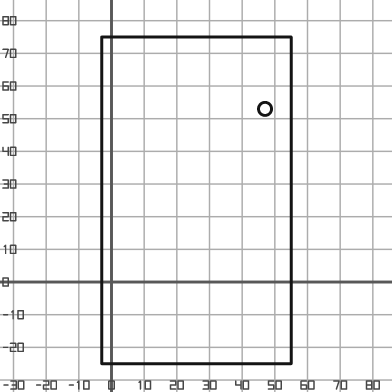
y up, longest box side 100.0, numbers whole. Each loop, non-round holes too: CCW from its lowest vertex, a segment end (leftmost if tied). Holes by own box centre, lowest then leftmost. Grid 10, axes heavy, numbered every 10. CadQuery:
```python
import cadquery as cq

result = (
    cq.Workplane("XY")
    .moveTo(-3.0, -25.0)
    .lineTo(55.0, -25.0)
    .lineTo(55.0, 75.0)
    .lineTo(-3.0, 75.0)
    .close()
    .moveTo(47.0, 53.0)
    .circle(2.0)
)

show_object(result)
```